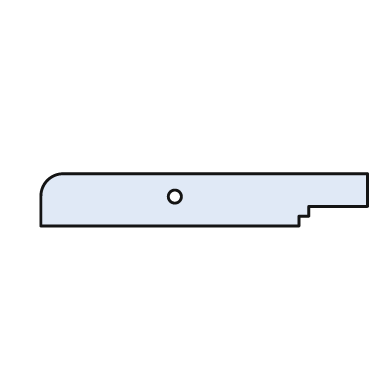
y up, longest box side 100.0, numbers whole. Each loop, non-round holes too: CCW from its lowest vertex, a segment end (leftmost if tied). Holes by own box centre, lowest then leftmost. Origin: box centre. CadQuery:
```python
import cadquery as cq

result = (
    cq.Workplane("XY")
    .moveTo(-50.0, -8.0)
    .lineTo(29.0, -8.0)
    .lineTo(29.0, -5.0)
    .lineTo(32.0, -5.0)
    .lineTo(32.0, -2.0)
    .lineTo(50.0, -2.0)
    .lineTo(50.0, 8.0)
    .lineTo(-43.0, 8.0)
    .threePointArc((-48.0, 6.0), (-50.0, 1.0))
    .close()
    .moveTo(-9.0, 1.0)
    .circle(2.0)
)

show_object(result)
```